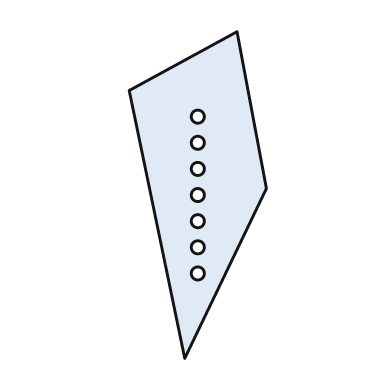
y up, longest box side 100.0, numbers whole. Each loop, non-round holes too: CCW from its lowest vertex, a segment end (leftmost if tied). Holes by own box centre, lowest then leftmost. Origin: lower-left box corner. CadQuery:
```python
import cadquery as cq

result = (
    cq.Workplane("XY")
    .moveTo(17.0, 0.0)
    .lineTo(42.0, 52.0)
    .lineTo(33.0, 100.0)
    .lineTo(0.0, 82.0)
    .close()
    .moveTo(21.0, 26.0)
    .circle(2.0)
    .moveTo(21.0, 34.0)
    .circle(2.0)
    .moveTo(21.0, 42.0)
    .circle(2.0)
    .moveTo(21.0, 50.0)
    .circle(2.0)
    .moveTo(21.0, 58.0)
    .circle(2.0)
    .moveTo(21.0, 66.0)
    .circle(2.0)
    .moveTo(21.0, 74.0)
    .circle(2.0)
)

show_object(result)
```